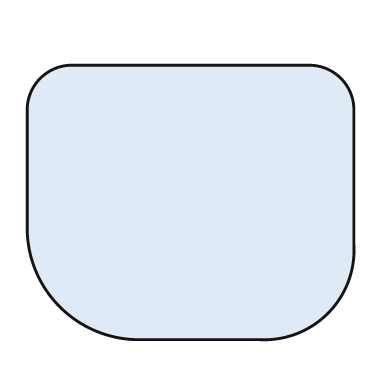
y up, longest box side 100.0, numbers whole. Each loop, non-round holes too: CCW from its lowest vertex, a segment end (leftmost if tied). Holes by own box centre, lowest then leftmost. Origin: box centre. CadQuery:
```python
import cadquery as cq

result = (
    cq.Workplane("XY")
    .moveTo(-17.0, -42.0)
    .lineTo(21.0, -42.0)
    .threePointArc((42.0, -34.0), (50.0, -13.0))
    .lineTo(50.0, 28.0)
    .threePointArc((46.0, 38.0), (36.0, 42.0))
    .lineTo(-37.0, 42.0)
    .threePointArc((-46.0, 38.0), (-50.0, 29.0))
    .lineTo(-50.0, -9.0)
    .threePointArc((-40.0, -32.0), (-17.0, -42.0))
    .close()
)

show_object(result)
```